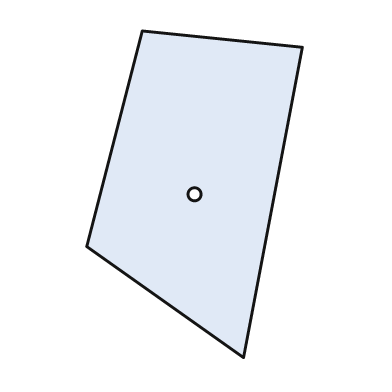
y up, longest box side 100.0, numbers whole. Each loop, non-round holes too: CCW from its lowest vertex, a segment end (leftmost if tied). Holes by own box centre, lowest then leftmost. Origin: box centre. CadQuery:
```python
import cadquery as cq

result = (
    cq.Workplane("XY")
    .moveTo(15.0, -50.0)
    .lineTo(33.0, 45.0)
    .lineTo(-16.0, 50.0)
    .lineTo(-33.0, -16.0)
    .close()
    .moveTo(0.0, 0.0)
    .circle(2.0)
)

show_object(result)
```